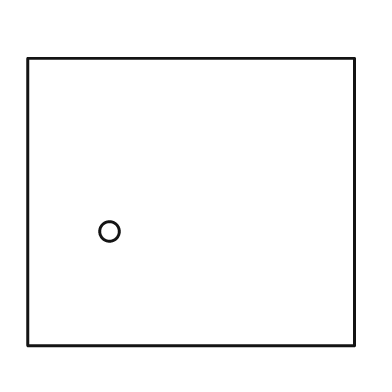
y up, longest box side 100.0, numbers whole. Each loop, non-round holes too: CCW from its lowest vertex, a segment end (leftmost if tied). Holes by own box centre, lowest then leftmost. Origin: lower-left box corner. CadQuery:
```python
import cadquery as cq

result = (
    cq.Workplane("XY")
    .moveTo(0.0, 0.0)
    .lineTo(100.0, 0.0)
    .lineTo(100.0, 88.0)
    .lineTo(0.0, 88.0)
    .close()
    .moveTo(25.0, 35.0)
    .circle(3.0)
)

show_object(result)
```